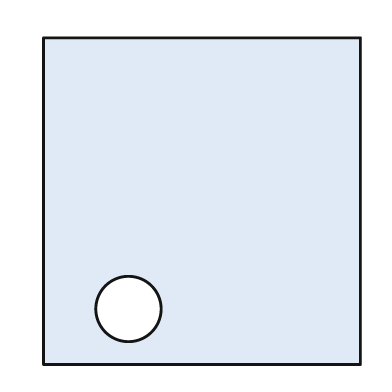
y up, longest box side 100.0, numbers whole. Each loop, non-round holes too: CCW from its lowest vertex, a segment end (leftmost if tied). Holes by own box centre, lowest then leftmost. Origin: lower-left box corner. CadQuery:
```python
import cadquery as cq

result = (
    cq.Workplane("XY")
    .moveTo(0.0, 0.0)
    .lineTo(97.0, 0.0)
    .lineTo(97.0, 100.0)
    .lineTo(0.0, 100.0)
    .close()
    .moveTo(26.0, 17.0)
    .circle(10.0)
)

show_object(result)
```